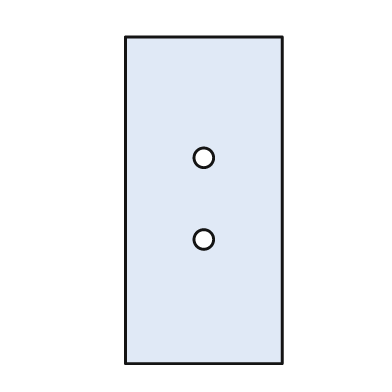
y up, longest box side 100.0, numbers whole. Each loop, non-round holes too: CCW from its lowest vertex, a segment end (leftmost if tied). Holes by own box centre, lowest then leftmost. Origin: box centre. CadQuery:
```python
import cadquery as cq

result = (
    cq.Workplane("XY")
    .moveTo(-24.0, -50.0)
    .lineTo(24.0, -50.0)
    .lineTo(24.0, 50.0)
    .lineTo(-24.0, 50.0)
    .close()
    .moveTo(0.0, -12.0)
    .circle(3.0)
    .moveTo(0.0, 13.0)
    .circle(3.0)
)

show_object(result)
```